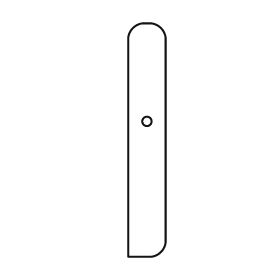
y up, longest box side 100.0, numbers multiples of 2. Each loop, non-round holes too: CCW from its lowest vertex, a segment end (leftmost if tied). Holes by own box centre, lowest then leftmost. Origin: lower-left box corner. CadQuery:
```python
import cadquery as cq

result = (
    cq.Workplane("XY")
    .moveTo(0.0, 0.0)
    .lineTo(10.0, 0.0)
    .threePointArc((14.0, 2.0), (16.0, 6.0))
    .lineTo(16.0, 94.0)
    .threePointArc((14.0, 98.0), (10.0, 100.0))
    .lineTo(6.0, 100.0)
    .threePointArc((2.0, 98.0), (0.0, 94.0))
    .close()
    .moveTo(8.0, 58.0)
    .circle(2.0)
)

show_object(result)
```